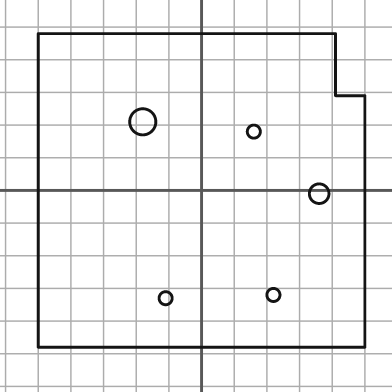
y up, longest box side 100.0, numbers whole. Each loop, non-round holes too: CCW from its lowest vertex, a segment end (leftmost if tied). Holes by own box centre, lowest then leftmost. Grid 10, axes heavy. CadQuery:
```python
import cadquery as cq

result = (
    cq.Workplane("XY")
    .moveTo(-50.0, -48.0)
    .lineTo(50.0, -48.0)
    .lineTo(50.0, 29.0)
    .lineTo(41.0, 29.0)
    .lineTo(41.0, 48.0)
    .lineTo(-50.0, 48.0)
    .close()
    .moveTo(-11.0, -33.0)
    .circle(2.0)
    .moveTo(22.0, -32.0)
    .circle(2.0)
    .moveTo(36.0, -1.0)
    .circle(3.0)
    .moveTo(16.0, 18.0)
    .circle(2.0)
    .moveTo(-18.0, 21.0)
    .circle(4.0)
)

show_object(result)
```